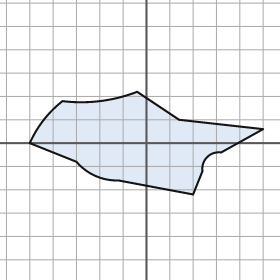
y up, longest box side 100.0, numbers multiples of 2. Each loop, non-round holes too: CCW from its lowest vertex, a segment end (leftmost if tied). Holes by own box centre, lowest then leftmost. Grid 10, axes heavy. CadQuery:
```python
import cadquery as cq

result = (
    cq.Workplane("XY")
    .moveTo(20.0, -22.0)
    .lineTo(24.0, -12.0)
    .threePointArc((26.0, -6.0), (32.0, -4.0))
    .lineTo(50.0, 6.0)
    .lineTo(14.0, 10.0)
    .lineTo(-4.0, 22.0)
    .threePointArc((-20.0, 18.0), (-36.0, 18.0))
    .threePointArc((-44.0, 10.0), (-50.0, 0.0))
    .lineTo(-30.0, -8.0)
    .threePointArc((-22.0, -14.0), (-12.0, -16.0))
    .close()
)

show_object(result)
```